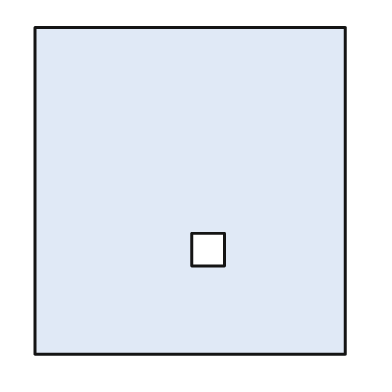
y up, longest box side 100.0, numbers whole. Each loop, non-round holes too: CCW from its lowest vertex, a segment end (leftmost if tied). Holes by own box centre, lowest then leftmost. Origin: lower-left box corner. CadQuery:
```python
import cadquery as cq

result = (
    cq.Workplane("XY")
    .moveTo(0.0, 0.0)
    .lineTo(95.0, 0.0)
    .lineTo(95.0, 100.0)
    .lineTo(0.0, 100.0)
    .close()
    .moveTo(48.0, 27.0)
    .lineTo(58.0, 27.0)
    .lineTo(58.0, 37.0)
    .lineTo(48.0, 37.0)
    .close()
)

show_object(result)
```